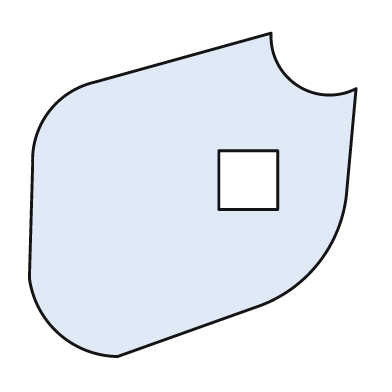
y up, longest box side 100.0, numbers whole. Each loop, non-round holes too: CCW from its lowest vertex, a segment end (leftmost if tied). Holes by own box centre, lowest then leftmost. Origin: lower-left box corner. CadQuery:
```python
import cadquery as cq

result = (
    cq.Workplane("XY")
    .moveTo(27.0, 0.0)
    .lineTo(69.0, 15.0)
    .threePointArc((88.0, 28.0), (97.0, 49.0))
    .lineTo(100.0, 82.0)
    .threePointArc((82.0, 83.0), (74.0, 99.0))
    .lineTo(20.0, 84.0)
    .threePointArc((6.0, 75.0), (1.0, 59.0))
    .lineTo(0.0, 24.0)
    .threePointArc((9.0, 7.0), (27.0, 0.0))
    .close()
    .moveTo(58.0, 45.0)
    .lineTo(76.0, 45.0)
    .lineTo(76.0, 63.0)
    .lineTo(58.0, 63.0)
    .close()
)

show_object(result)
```